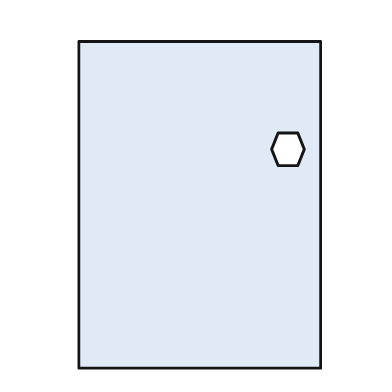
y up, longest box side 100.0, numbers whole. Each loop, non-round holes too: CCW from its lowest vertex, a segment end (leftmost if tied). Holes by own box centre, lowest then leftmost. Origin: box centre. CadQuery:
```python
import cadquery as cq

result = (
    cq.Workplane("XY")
    .moveTo(-37.0, -50.0)
    .lineTo(37.0, -50.0)
    .lineTo(37.0, 50.0)
    .lineTo(-37.0, 50.0)
    .close()
    .moveTo(24.0, 12.0)
    .lineTo(30.0, 12.0)
    .lineTo(32.0, 17.0)
    .lineTo(30.0, 22.0)
    .lineTo(24.0, 22.0)
    .lineTo(22.0, 17.0)
    .close()
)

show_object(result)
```